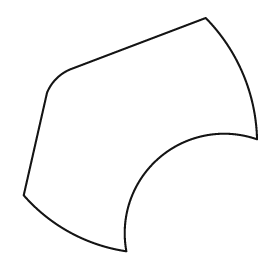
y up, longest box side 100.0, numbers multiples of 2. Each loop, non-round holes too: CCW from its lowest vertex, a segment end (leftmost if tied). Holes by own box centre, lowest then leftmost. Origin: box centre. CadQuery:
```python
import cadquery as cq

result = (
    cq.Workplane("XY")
    .moveTo(-6.0, -50.0)
    .threePointArc((8.0, -10.0), (50.0, -2.0))
    .threePointArc((44.0, 26.0), (28.0, 50.0))
    .lineTo(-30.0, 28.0)
    .threePointArc((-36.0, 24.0), (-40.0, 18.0))
    .lineTo(-50.0, -26.0)
    .threePointArc((-30.0, -42.0), (-6.0, -50.0))
    .close()
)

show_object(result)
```